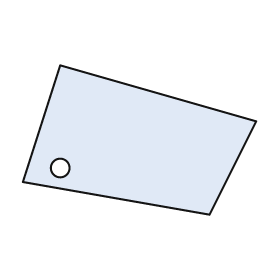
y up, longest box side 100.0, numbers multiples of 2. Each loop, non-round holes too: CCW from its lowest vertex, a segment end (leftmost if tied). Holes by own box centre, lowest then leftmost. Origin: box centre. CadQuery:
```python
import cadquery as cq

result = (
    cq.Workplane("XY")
    .moveTo(30.0, -32.0)
    .lineTo(50.0, 8.0)
    .lineTo(-34.0, 32.0)
    .lineTo(-50.0, -18.0)
    .close()
    .moveTo(-34.0, -12.0)
    .circle(4.0)
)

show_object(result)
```